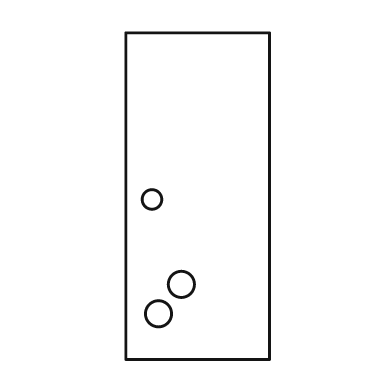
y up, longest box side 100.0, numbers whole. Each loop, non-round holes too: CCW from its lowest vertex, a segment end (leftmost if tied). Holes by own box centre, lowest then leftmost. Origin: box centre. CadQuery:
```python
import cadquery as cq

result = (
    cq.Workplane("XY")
    .moveTo(-22.0, -50.0)
    .lineTo(22.0, -50.0)
    .lineTo(22.0, 50.0)
    .lineTo(-22.0, 50.0)
    .close()
    .moveTo(-12.0, -36.0)
    .circle(4.0)
    .moveTo(-5.0, -27.0)
    .circle(4.0)
    .moveTo(-14.0, -1.0)
    .circle(3.0)
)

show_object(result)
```